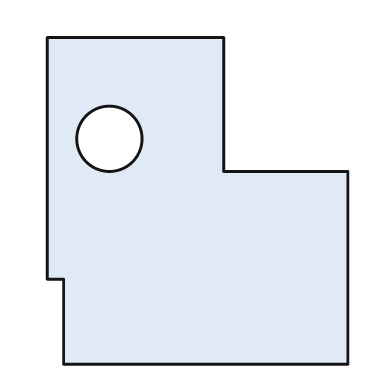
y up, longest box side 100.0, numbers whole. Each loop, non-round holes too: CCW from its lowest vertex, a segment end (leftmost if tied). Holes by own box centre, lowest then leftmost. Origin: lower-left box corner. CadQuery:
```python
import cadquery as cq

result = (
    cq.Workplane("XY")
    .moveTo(5.0, 0.0)
    .lineTo(92.0, 0.0)
    .lineTo(92.0, 59.0)
    .lineTo(54.0, 59.0)
    .lineTo(54.0, 100.0)
    .lineTo(0.0, 100.0)
    .lineTo(0.0, 26.0)
    .lineTo(5.0, 26.0)
    .close()
    .moveTo(19.0, 69.0)
    .circle(10.0)
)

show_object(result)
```